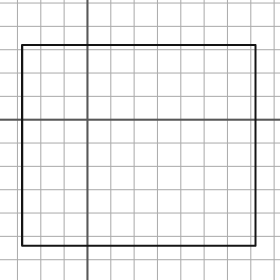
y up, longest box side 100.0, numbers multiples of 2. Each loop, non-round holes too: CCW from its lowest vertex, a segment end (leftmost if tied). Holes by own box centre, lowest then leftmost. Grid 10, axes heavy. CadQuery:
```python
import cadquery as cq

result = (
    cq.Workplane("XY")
    .moveTo(-28.0, -54.0)
    .lineTo(72.0, -54.0)
    .lineTo(72.0, 32.0)
    .lineTo(-28.0, 32.0)
    .close()
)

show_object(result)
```